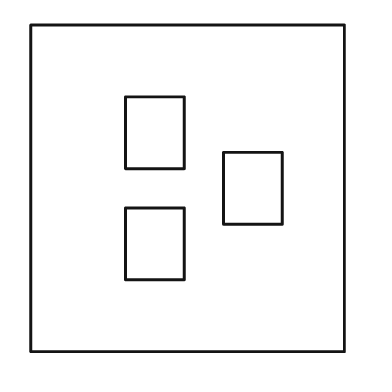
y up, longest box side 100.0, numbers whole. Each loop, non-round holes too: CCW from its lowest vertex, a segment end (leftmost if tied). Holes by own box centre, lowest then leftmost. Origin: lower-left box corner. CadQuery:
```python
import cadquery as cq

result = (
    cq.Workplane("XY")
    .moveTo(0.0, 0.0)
    .lineTo(96.0, 0.0)
    .lineTo(96.0, 100.0)
    .lineTo(0.0, 100.0)
    .close()
    .moveTo(29.0, 22.0)
    .lineTo(47.0, 22.0)
    .lineTo(47.0, 44.0)
    .lineTo(29.0, 44.0)
    .close()
    .moveTo(59.0, 39.0)
    .lineTo(77.0, 39.0)
    .lineTo(77.0, 61.0)
    .lineTo(59.0, 61.0)
    .close()
    .moveTo(29.0, 56.0)
    .lineTo(47.0, 56.0)
    .lineTo(47.0, 78.0)
    .lineTo(29.0, 78.0)
    .close()
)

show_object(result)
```